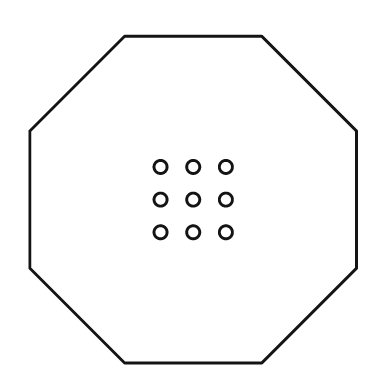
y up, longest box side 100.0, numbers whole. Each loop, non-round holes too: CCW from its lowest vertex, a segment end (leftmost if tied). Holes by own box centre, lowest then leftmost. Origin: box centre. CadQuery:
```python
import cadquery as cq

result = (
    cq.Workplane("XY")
    .moveTo(-21.0, -50.0)
    .lineTo(21.0, -50.0)
    .lineTo(50.0, -21.0)
    .lineTo(50.0, 21.0)
    .lineTo(21.0, 50.0)
    .lineTo(-21.0, 50.0)
    .lineTo(-50.0, 21.0)
    .lineTo(-50.0, -21.0)
    .close()
    .moveTo(-10.0, -10.0)
    .circle(2.0)
    .moveTo(0.0, -10.0)
    .circle(2.0)
    .moveTo(10.0, -10.0)
    .circle(2.0)
    .moveTo(-10.0, 0.0)
    .circle(2.0)
    .moveTo(0.0, 0.0)
    .circle(2.0)
    .moveTo(10.0, 0.0)
    .circle(2.0)
    .moveTo(-10.0, 10.0)
    .circle(2.0)
    .moveTo(0.0, 10.0)
    .circle(2.0)
    .moveTo(10.0, 10.0)
    .circle(2.0)
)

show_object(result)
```